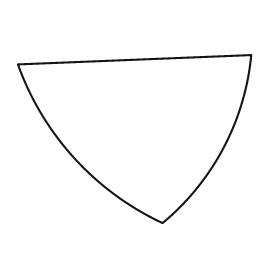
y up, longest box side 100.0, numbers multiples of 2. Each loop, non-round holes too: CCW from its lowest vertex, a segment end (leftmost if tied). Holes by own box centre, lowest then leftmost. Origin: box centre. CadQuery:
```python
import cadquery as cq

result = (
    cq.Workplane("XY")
    .moveTo(12.0, -36.0)
    .threePointArc((38.0, -4.0), (50.0, 36.0))
    .lineTo(-50.0, 32.0)
    .threePointArc((-26.0, -8.0), (12.0, -36.0))
    .close()
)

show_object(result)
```